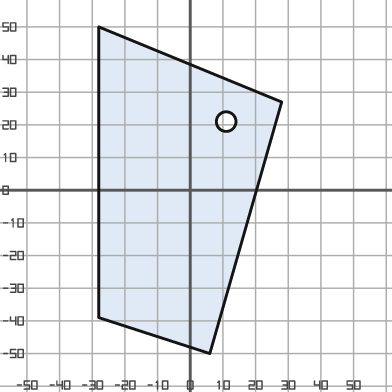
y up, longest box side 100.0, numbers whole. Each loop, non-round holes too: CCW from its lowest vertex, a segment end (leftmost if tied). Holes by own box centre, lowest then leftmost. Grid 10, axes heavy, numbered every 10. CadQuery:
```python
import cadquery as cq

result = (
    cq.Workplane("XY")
    .moveTo(6.0, -50.0)
    .lineTo(28.0, 27.0)
    .lineTo(-28.0, 50.0)
    .lineTo(-28.0, -39.0)
    .close()
    .moveTo(11.0, 21.0)
    .circle(3.0)
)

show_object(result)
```